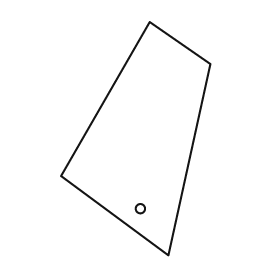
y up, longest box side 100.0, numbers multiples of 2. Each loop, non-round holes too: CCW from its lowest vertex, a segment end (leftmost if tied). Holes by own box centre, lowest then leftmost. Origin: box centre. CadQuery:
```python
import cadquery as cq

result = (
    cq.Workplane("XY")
    .moveTo(14.0, -50.0)
    .lineTo(32.0, 32.0)
    .lineTo(6.0, 50.0)
    .lineTo(-32.0, -16.0)
    .close()
    .moveTo(2.0, -30.0)
    .circle(2.0)
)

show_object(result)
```